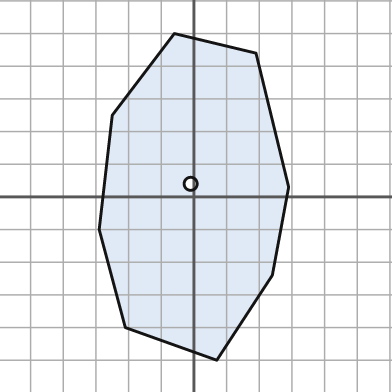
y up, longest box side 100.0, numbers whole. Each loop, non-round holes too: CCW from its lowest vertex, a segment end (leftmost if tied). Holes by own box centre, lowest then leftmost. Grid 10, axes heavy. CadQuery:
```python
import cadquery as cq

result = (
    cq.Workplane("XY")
    .moveTo(7.0, -50.0)
    .lineTo(24.0, -24.0)
    .lineTo(29.0, 3.0)
    .lineTo(19.0, 44.0)
    .lineTo(-6.0, 50.0)
    .lineTo(-25.0, 25.0)
    .lineTo(-29.0, -10.0)
    .lineTo(-21.0, -40.0)
    .close()
    .moveTo(-1.0, 4.0)
    .circle(2.0)
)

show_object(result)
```